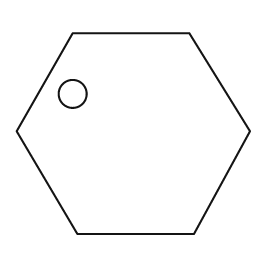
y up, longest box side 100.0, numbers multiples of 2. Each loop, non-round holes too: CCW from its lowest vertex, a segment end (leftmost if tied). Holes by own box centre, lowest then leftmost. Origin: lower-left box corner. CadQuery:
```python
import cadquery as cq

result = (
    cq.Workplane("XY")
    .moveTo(26.0, 0.0)
    .lineTo(76.0, 0.0)
    .lineTo(100.0, 44.0)
    .lineTo(74.0, 86.0)
    .lineTo(24.0, 86.0)
    .lineTo(0.0, 44.0)
    .close()
    .moveTo(24.0, 60.0)
    .circle(6.0)
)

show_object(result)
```